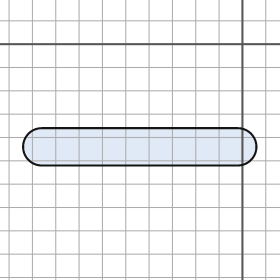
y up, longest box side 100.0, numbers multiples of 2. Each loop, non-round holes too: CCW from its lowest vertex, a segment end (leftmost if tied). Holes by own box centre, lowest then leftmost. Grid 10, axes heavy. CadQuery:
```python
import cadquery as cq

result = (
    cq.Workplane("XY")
    .moveTo(-86.0, -52.0)
    .lineTo(-2.0, -52.0)
    .threePointArc((6.0, -44.0), (-2.0, -36.0))
    .lineTo(-86.0, -36.0)
    .threePointArc((-94.0, -44.0), (-86.0, -52.0))
    .close()
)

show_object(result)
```